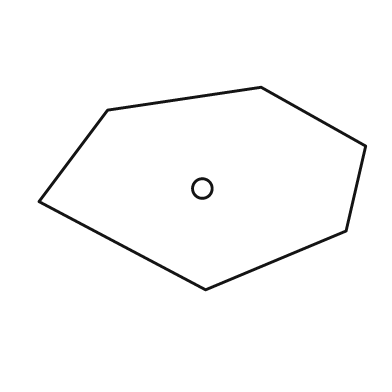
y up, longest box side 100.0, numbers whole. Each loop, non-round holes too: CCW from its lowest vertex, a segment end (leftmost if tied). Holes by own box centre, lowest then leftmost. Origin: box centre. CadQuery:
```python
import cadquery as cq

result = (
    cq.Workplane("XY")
    .moveTo(1.0, -31.0)
    .lineTo(44.0, -13.0)
    .lineTo(50.0, 13.0)
    .lineTo(18.0, 31.0)
    .lineTo(-29.0, 24.0)
    .lineTo(-50.0, -4.0)
    .close()
    .moveTo(0.0, 0.0)
    .circle(3.0)
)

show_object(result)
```